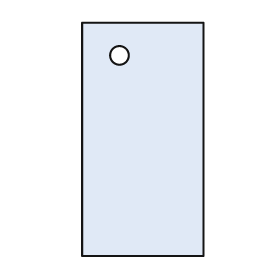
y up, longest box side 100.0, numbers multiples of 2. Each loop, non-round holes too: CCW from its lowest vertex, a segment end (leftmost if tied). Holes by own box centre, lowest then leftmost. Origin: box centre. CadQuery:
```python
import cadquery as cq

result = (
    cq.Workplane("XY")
    .moveTo(-26.0, -50.0)
    .lineTo(26.0, -50.0)
    .lineTo(26.0, 50.0)
    .lineTo(-26.0, 50.0)
    .close()
    .moveTo(-10.0, 36.0)
    .circle(4.0)
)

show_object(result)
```